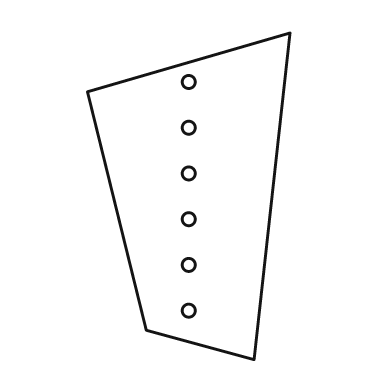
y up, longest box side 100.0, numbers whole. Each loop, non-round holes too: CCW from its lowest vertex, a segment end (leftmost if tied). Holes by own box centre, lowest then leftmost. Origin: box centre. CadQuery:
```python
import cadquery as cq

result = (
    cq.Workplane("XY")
    .moveTo(20.0, -50.0)
    .lineTo(31.0, 50.0)
    .lineTo(-31.0, 32.0)
    .lineTo(-13.0, -41.0)
    .close()
    .moveTo(0.0, -35.0)
    .circle(2.0)
    .moveTo(0.0, -21.0)
    .circle(2.0)
    .moveTo(0.0, -7.0)
    .circle(2.0)
    .moveTo(0.0, 7.0)
    .circle(2.0)
    .moveTo(0.0, 21.0)
    .circle(2.0)
    .moveTo(0.0, 35.0)
    .circle(2.0)
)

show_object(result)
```